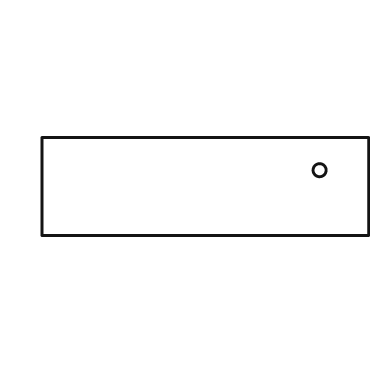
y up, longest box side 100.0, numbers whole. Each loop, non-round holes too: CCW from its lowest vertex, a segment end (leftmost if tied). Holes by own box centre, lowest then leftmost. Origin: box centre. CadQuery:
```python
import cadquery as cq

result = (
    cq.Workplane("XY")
    .moveTo(-50.0, -15.0)
    .lineTo(50.0, -15.0)
    .lineTo(50.0, 15.0)
    .lineTo(-50.0, 15.0)
    .close()
    .moveTo(35.0, 5.0)
    .circle(2.0)
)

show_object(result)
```